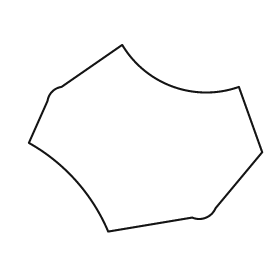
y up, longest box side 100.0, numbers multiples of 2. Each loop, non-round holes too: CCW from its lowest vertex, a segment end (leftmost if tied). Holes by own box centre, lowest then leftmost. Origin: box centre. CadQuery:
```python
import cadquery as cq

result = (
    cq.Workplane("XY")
    .moveTo(-16.0, -40.0)
    .lineTo(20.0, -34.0)
    .threePointArc((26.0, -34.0), (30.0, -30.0))
    .lineTo(50.0, -6.0)
    .lineTo(40.0, 22.0)
    .threePointArc((12.0, 22.0), (-10.0, 40.0))
    .lineTo(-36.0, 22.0)
    .threePointArc((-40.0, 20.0), (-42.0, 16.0))
    .lineTo(-50.0, -2.0)
    .threePointArc((-30.0, -18.0), (-16.0, -40.0))
    .close()
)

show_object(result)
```